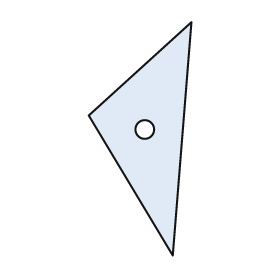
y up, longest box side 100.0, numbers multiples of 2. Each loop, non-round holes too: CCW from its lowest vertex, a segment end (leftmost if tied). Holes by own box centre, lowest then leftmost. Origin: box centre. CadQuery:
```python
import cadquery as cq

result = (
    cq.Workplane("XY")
    .moveTo(14.0, -50.0)
    .lineTo(22.0, 50.0)
    .lineTo(-22.0, 10.0)
    .close()
    .moveTo(2.0, 4.0)
    .circle(4.0)
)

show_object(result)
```